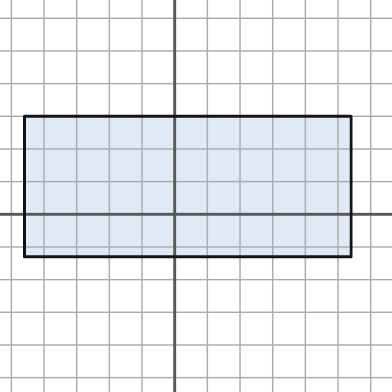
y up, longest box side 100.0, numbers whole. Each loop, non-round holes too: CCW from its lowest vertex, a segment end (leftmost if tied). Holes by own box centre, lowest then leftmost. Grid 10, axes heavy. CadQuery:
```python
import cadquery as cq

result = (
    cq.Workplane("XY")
    .moveTo(-46.0, -13.0)
    .lineTo(54.0, -13.0)
    .lineTo(54.0, 30.0)
    .lineTo(-46.0, 30.0)
    .close()
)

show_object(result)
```